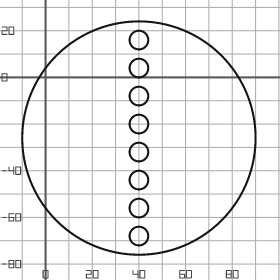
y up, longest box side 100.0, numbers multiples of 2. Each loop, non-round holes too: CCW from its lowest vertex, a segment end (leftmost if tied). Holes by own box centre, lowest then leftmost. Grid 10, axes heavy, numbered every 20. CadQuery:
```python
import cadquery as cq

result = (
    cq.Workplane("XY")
    .moveTo(40.0, -26.0)
    .circle(50.0)
    .moveTo(40.0, -68.0)
    .circle(4.0)
    .moveTo(40.0, -56.0)
    .circle(4.0)
    .moveTo(40.0, -44.0)
    .circle(4.0)
    .moveTo(40.0, -32.0)
    .circle(4.0)
    .moveTo(40.0, -20.0)
    .circle(4.0)
    .moveTo(40.0, -8.0)
    .circle(4.0)
    .moveTo(40.0, 4.0)
    .circle(4.0)
    .moveTo(40.0, 16.0)
    .circle(4.0)
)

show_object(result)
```